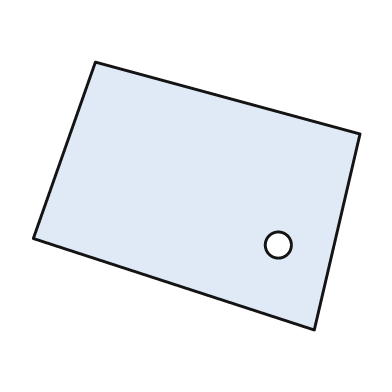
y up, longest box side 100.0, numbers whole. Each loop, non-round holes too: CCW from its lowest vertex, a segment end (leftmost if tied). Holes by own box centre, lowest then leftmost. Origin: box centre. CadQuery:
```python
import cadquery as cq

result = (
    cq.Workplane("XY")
    .moveTo(36.0, -41.0)
    .lineTo(50.0, 19.0)
    .lineTo(-31.0, 41.0)
    .lineTo(-50.0, -13.0)
    .close()
    .moveTo(25.0, -15.0)
    .circle(4.0)
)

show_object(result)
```